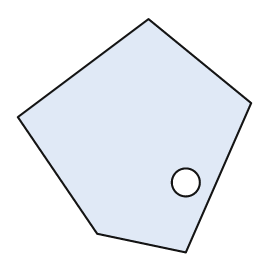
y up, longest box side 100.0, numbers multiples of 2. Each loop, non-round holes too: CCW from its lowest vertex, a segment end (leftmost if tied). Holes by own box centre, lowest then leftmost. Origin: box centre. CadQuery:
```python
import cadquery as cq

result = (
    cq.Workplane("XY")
    .moveTo(22.0, -50.0)
    .lineTo(50.0, 14.0)
    .lineTo(6.0, 50.0)
    .lineTo(-50.0, 8.0)
    .lineTo(-16.0, -42.0)
    .close()
    .moveTo(22.0, -20.0)
    .circle(6.0)
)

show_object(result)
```